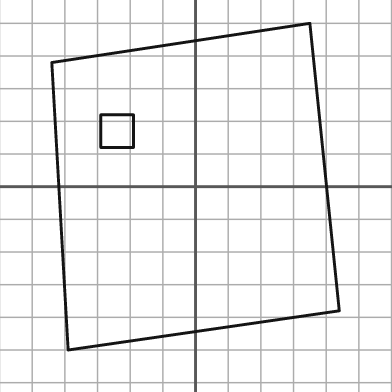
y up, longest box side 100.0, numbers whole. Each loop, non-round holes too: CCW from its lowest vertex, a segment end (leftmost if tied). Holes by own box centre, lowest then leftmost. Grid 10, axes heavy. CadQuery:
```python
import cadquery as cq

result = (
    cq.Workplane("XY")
    .moveTo(-39.0, -50.0)
    .lineTo(44.0, -38.0)
    .lineTo(35.0, 50.0)
    .lineTo(-44.0, 38.0)
    .close()
    .moveTo(-29.0, 12.0)
    .lineTo(-19.0, 12.0)
    .lineTo(-19.0, 22.0)
    .lineTo(-29.0, 22.0)
    .close()
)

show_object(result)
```